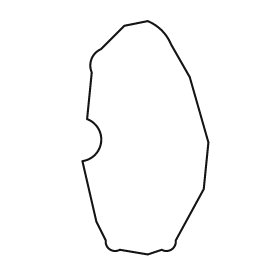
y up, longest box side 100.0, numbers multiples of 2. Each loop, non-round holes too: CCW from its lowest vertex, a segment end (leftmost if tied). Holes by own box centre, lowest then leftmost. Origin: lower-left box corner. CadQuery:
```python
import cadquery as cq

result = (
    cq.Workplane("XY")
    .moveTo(28.0, 0.0)
    .lineTo(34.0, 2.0)
    .threePointArc((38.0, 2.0), (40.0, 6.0))
    .lineTo(52.0, 28.0)
    .lineTo(54.0, 48.0)
    .lineTo(46.0, 76.0)
    .lineTo(38.0, 90.0)
    .threePointArc((34.0, 96.0), (28.0, 100.0))
    .lineTo(18.0, 98.0)
    .lineTo(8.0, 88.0)
    .threePointArc((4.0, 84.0), (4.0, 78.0))
    .lineTo(2.0, 58.0)
    .threePointArc((8.0, 48.0), (0.0, 40.0))
    .lineTo(6.0, 14.0)
    .lineTo(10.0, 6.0)
    .threePointArc((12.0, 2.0), (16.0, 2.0))
    .close()
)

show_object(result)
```